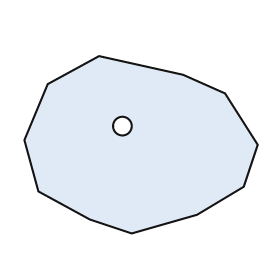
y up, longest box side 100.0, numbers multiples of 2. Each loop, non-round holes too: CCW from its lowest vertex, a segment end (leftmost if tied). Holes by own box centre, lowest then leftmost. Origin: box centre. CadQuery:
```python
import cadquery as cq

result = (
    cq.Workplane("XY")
    .moveTo(-4.0, -38.0)
    .lineTo(24.0, -30.0)
    .lineTo(44.0, -18.0)
    .lineTo(50.0, 0.0)
    .lineTo(36.0, 22.0)
    .lineTo(18.0, 30.0)
    .lineTo(-18.0, 38.0)
    .lineTo(-40.0, 26.0)
    .lineTo(-50.0, 2.0)
    .lineTo(-44.0, -20.0)
    .lineTo(-22.0, -32.0)
    .close()
    .moveTo(-8.0, 8.0)
    .circle(4.0)
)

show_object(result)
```